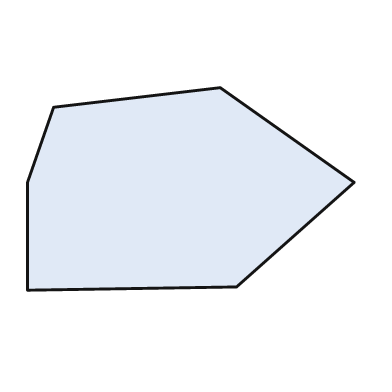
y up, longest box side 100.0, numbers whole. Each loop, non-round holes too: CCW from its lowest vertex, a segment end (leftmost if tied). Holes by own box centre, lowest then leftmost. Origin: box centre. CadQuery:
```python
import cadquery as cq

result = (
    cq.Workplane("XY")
    .moveTo(-50.0, -31.0)
    .lineTo(14.0, -30.0)
    .lineTo(50.0, 2.0)
    .lineTo(9.0, 31.0)
    .lineTo(-42.0, 25.0)
    .lineTo(-50.0, 2.0)
    .close()
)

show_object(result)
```